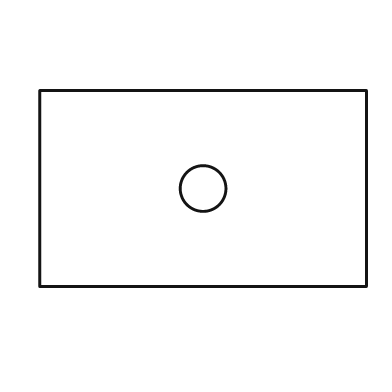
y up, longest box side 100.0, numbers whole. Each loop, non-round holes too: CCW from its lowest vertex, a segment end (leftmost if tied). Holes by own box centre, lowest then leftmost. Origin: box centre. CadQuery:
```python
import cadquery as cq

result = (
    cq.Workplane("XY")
    .moveTo(-50.0, -30.0)
    .lineTo(50.0, -30.0)
    .lineTo(50.0, 30.0)
    .lineTo(-50.0, 30.0)
    .close()
    .moveTo(0.0, 0.0)
    .circle(7.0)
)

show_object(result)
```